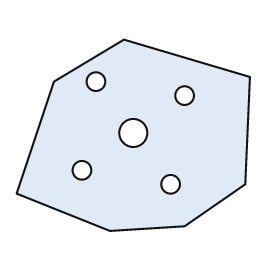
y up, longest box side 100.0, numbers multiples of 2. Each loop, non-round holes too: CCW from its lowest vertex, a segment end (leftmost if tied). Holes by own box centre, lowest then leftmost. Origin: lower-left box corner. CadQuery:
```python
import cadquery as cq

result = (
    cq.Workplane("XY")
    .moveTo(40.0, 0.0)
    .lineTo(72.0, 2.0)
    .lineTo(98.0, 20.0)
    .lineTo(100.0, 66.0)
    .lineTo(46.0, 82.0)
    .lineTo(16.0, 64.0)
    .lineTo(0.0, 16.0)
    .close()
    .moveTo(66.0, 20.0)
    .circle(4.0)
    .moveTo(28.0, 26.0)
    .circle(4.0)
    .moveTo(50.0, 42.0)
    .circle(6.0)
    .moveTo(72.0, 58.0)
    .circle(4.0)
    .moveTo(34.0, 64.0)
    .circle(4.0)
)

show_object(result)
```